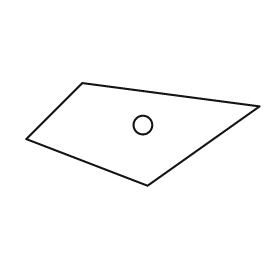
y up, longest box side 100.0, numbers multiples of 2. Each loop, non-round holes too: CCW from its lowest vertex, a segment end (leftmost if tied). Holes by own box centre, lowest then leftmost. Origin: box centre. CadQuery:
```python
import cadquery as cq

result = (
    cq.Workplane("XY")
    .moveTo(2.0, -22.0)
    .lineTo(50.0, 12.0)
    .lineTo(-26.0, 22.0)
    .lineTo(-50.0, -2.0)
    .close()
    .moveTo(0.0, 4.0)
    .circle(4.0)
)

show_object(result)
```